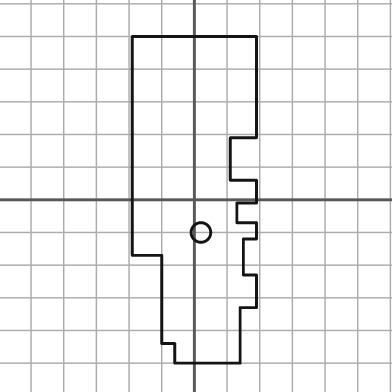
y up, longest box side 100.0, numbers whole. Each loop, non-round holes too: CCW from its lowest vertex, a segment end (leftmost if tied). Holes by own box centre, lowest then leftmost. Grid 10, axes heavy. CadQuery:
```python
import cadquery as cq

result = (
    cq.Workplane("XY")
    .moveTo(-6.0, -50.0)
    .lineTo(14.0, -50.0)
    .lineTo(14.0, -33.0)
    .lineTo(19.0, -33.0)
    .lineTo(19.0, -23.0)
    .lineTo(15.0, -23.0)
    .lineTo(15.0, -12.0)
    .lineTo(19.0, -12.0)
    .lineTo(19.0, -7.0)
    .lineTo(13.0, -7.0)
    .lineTo(13.0, -1.0)
    .lineTo(19.0, -1.0)
    .lineTo(19.0, 6.0)
    .lineTo(11.0, 6.0)
    .lineTo(11.0, 19.0)
    .lineTo(19.0, 19.0)
    .lineTo(19.0, 50.0)
    .lineTo(-19.0, 50.0)
    .lineTo(-19.0, -17.0)
    .lineTo(-10.0, -17.0)
    .lineTo(-10.0, -44.0)
    .lineTo(-6.0, -44.0)
    .close()
    .moveTo(2.0, -10.0)
    .circle(3.0)
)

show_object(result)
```